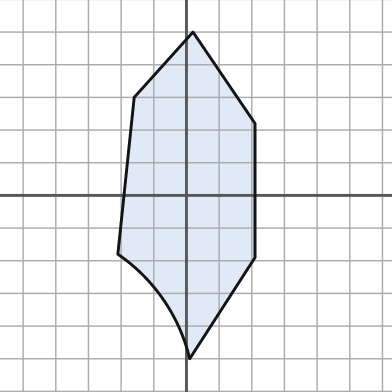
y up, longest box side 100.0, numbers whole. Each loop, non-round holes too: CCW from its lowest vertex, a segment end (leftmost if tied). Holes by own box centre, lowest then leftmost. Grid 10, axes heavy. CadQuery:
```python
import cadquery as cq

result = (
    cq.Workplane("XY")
    .moveTo(1.0, -50.0)
    .lineTo(21.0, -19.0)
    .lineTo(21.0, 22.0)
    .lineTo(2.0, 50.0)
    .lineTo(-16.0, 30.0)
    .lineTo(-21.0, -18.0)
    .threePointArc((-7.0, -32.0), (1.0, -50.0))
    .close()
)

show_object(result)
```